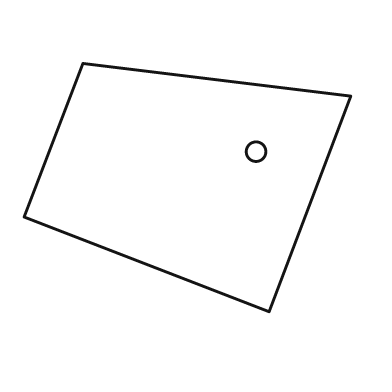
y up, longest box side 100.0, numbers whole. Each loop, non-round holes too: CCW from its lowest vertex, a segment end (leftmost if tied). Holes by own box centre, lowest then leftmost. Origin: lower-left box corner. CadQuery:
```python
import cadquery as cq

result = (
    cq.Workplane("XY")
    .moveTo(75.0, 0.0)
    .lineTo(100.0, 66.0)
    .lineTo(18.0, 76.0)
    .lineTo(0.0, 29.0)
    .close()
    .moveTo(71.0, 49.0)
    .circle(3.0)
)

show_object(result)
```